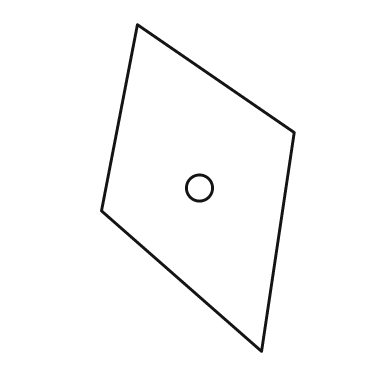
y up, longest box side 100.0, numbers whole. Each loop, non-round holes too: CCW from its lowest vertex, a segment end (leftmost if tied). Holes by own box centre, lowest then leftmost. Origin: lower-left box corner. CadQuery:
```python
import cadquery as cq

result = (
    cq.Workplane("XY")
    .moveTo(49.0, 0.0)
    .lineTo(59.0, 67.0)
    .lineTo(11.0, 100.0)
    .lineTo(0.0, 43.0)
    .close()
    .moveTo(30.0, 50.0)
    .circle(4.0)
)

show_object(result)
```